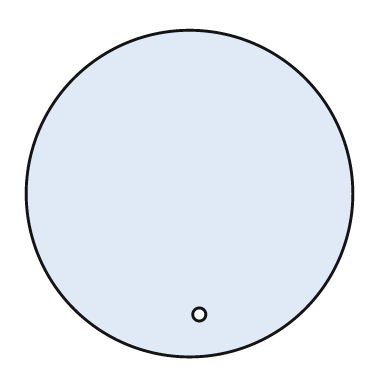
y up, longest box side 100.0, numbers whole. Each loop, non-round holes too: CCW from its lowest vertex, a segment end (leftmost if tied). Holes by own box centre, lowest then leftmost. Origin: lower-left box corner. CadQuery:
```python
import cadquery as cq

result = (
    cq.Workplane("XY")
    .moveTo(50.0, 50.0)
    .circle(50.0)
    .moveTo(53.0, 13.0)
    .circle(2.0)
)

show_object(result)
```